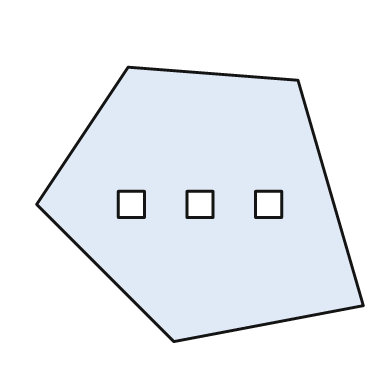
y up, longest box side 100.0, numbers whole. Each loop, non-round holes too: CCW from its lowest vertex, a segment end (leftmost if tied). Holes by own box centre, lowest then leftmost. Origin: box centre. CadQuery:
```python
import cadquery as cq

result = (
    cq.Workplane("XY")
    .moveTo(-8.0, -42.0)
    .lineTo(50.0, -31.0)
    .lineTo(30.0, 38.0)
    .lineTo(-22.0, 42.0)
    .lineTo(-50.0, 0.0)
    .close()
    .moveTo(-25.0, -4.0)
    .lineTo(-17.0, -4.0)
    .lineTo(-17.0, 4.0)
    .lineTo(-25.0, 4.0)
    .close()
    .moveTo(-4.0, -4.0)
    .lineTo(4.0, -4.0)
    .lineTo(4.0, 4.0)
    .lineTo(-4.0, 4.0)
    .close()
    .moveTo(17.0, -4.0)
    .lineTo(25.0, -4.0)
    .lineTo(25.0, 4.0)
    .lineTo(17.0, 4.0)
    .close()
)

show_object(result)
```